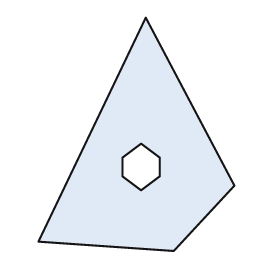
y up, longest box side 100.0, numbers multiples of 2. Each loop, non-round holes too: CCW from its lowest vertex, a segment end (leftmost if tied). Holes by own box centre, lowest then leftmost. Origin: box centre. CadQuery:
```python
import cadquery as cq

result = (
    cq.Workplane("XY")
    .moveTo(16.0, -50.0)
    .lineTo(42.0, -22.0)
    .lineTo(4.0, 50.0)
    .lineTo(-42.0, -46.0)
    .close()
    .moveTo(2.0, -24.0)
    .lineTo(10.0, -18.0)
    .lineTo(10.0, -10.0)
    .lineTo(2.0, -4.0)
    .lineTo(-6.0, -10.0)
    .lineTo(-6.0, -18.0)
    .close()
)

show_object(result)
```